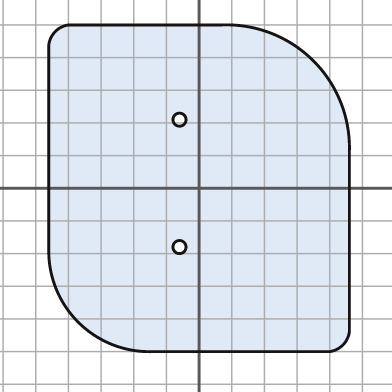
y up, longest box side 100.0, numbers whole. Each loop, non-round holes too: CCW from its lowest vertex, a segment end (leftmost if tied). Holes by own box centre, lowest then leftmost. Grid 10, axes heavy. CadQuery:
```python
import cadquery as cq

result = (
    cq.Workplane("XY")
    .moveTo(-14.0, -50.0)
    .lineTo(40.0, -50.0)
    .threePointArc((44.0, -48.0), (46.0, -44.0))
    .lineTo(46.0, 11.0)
    .threePointArc((35.0, 39.0), (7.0, 50.0))
    .lineTo(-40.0, 50.0)
    .threePointArc((-44.0, 48.0), (-46.0, 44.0))
    .lineTo(-46.0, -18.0)
    .threePointArc((-37.0, -41.0), (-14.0, -50.0))
    .close()
    .moveTo(-6.0, -18.0)
    .circle(2.0)
    .moveTo(-6.0, 21.0)
    .circle(2.0)
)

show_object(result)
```